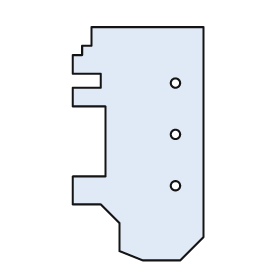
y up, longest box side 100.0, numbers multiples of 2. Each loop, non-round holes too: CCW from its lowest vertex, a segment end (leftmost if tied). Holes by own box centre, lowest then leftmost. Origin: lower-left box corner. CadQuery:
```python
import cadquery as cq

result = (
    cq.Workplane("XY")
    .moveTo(30.0, 0.0)
    .lineTo(46.0, 0.0)
    .lineTo(56.0, 10.0)
    .lineTo(56.0, 100.0)
    .lineTo(8.0, 100.0)
    .lineTo(8.0, 92.0)
    .lineTo(4.0, 92.0)
    .lineTo(4.0, 88.0)
    .lineTo(0.0, 88.0)
    .lineTo(0.0, 80.0)
    .lineTo(12.0, 80.0)
    .lineTo(12.0, 74.0)
    .lineTo(0.0, 74.0)
    .lineTo(0.0, 66.0)
    .lineTo(14.0, 66.0)
    .lineTo(14.0, 36.0)
    .lineTo(0.0, 36.0)
    .lineTo(0.0, 24.0)
    .lineTo(12.0, 24.0)
    .lineTo(20.0, 16.0)
    .lineTo(20.0, 4.0)
    .close()
    .moveTo(44.0, 32.0)
    .circle(2.0)
    .moveTo(44.0, 54.0)
    .circle(2.0)
    .moveTo(44.0, 76.0)
    .circle(2.0)
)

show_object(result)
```